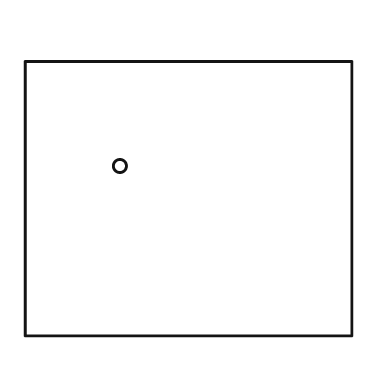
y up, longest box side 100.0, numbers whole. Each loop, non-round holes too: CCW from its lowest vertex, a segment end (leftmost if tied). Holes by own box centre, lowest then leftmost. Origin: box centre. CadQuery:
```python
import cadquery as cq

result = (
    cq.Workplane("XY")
    .moveTo(-50.0, -42.0)
    .lineTo(50.0, -42.0)
    .lineTo(50.0, 42.0)
    .lineTo(-50.0, 42.0)
    .close()
    .moveTo(-21.0, 10.0)
    .circle(2.0)
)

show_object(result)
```